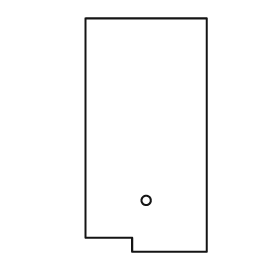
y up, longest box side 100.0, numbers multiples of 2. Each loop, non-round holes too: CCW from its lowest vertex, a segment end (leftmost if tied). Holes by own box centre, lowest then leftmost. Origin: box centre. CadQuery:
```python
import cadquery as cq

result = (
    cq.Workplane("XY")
    .moveTo(-6.0, -50.0)
    .lineTo(26.0, -50.0)
    .lineTo(26.0, 50.0)
    .lineTo(-26.0, 50.0)
    .lineTo(-26.0, -44.0)
    .lineTo(-6.0, -44.0)
    .close()
    .moveTo(0.0, -28.0)
    .circle(2.0)
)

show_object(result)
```